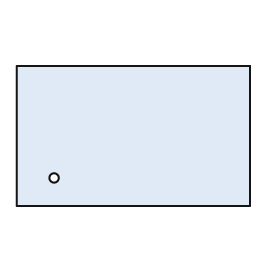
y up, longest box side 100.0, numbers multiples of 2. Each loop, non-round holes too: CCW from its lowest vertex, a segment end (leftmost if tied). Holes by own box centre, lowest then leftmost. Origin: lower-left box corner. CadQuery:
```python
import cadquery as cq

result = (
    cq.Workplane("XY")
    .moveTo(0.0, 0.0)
    .lineTo(100.0, 0.0)
    .lineTo(100.0, 60.0)
    .lineTo(0.0, 60.0)
    .close()
    .moveTo(16.0, 12.0)
    .circle(2.0)
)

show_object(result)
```